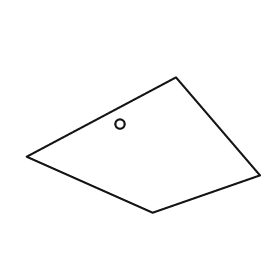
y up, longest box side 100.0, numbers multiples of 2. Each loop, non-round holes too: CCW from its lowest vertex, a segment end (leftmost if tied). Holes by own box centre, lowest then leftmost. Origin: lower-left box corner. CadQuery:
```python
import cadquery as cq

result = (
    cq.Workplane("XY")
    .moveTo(54.0, 0.0)
    .lineTo(100.0, 16.0)
    .lineTo(64.0, 58.0)
    .lineTo(0.0, 24.0)
    .close()
    .moveTo(40.0, 38.0)
    .circle(2.0)
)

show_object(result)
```